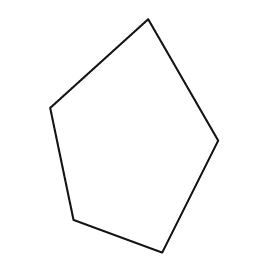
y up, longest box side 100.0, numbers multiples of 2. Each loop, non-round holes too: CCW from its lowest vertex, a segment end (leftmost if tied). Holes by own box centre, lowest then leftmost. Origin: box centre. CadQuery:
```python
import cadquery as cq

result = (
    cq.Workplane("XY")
    .moveTo(12.0, -50.0)
    .lineTo(36.0, -2.0)
    .lineTo(6.0, 50.0)
    .lineTo(-36.0, 12.0)
    .lineTo(-26.0, -36.0)
    .close()
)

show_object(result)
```